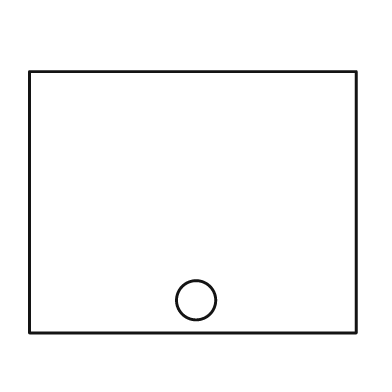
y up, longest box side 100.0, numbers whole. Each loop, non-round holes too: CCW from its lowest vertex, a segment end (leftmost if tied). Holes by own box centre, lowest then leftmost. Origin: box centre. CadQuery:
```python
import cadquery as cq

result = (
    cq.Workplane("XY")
    .moveTo(-50.0, -40.0)
    .lineTo(50.0, -40.0)
    .lineTo(50.0, 40.0)
    .lineTo(-50.0, 40.0)
    .close()
    .moveTo(1.0, -30.0)
    .circle(6.0)
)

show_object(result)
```